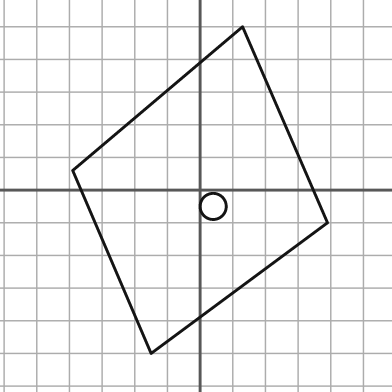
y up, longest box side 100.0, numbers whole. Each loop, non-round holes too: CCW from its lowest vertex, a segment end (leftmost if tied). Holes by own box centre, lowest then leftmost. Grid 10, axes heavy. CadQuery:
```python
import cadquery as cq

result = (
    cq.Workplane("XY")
    .moveTo(-15.0, -50.0)
    .lineTo(39.0, -10.0)
    .lineTo(13.0, 50.0)
    .lineTo(-39.0, 6.0)
    .close()
    .moveTo(4.0, -5.0)
    .circle(4.0)
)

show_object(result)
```